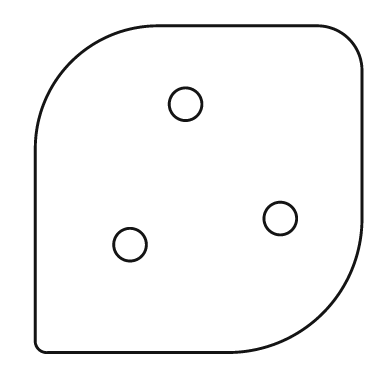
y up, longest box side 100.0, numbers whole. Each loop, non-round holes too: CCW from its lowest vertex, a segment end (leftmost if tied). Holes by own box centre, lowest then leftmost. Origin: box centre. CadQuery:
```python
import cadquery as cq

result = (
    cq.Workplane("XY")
    .moveTo(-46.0, -50.0)
    .lineTo(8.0, -50.0)
    .threePointArc((38.0, -38.0), (50.0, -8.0))
    .lineTo(50.0, 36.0)
    .threePointArc((46.0, 46.0), (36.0, 50.0))
    .lineTo(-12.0, 50.0)
    .threePointArc((-39.0, 39.0), (-50.0, 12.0))
    .lineTo(-50.0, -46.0)
    .threePointArc((-49.0, -49.0), (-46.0, -50.0))
    .close()
    .moveTo(-21.0, -17.0)
    .circle(5.0)
    .moveTo(25.0, -9.0)
    .circle(5.0)
    .moveTo(-4.0, 26.0)
    .circle(5.0)
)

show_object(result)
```